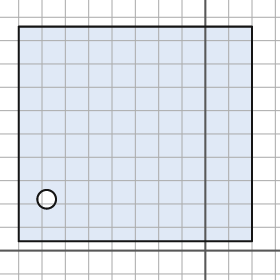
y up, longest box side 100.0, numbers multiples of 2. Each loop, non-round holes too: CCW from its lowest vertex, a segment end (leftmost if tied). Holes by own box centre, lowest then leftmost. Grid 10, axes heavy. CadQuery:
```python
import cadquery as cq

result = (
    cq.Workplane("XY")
    .moveTo(-80.0, 4.0)
    .lineTo(20.0, 4.0)
    .lineTo(20.0, 96.0)
    .lineTo(-80.0, 96.0)
    .close()
    .moveTo(-68.0, 22.0)
    .circle(4.0)
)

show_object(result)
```